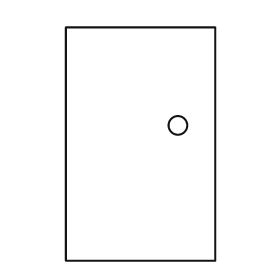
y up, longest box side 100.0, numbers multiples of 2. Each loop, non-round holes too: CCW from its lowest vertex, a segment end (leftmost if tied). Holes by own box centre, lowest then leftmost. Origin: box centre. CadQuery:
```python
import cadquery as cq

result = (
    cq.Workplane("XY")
    .moveTo(-32.0, -50.0)
    .lineTo(32.0, -50.0)
    .lineTo(32.0, 50.0)
    .lineTo(-32.0, 50.0)
    .close()
    .moveTo(16.0, 8.0)
    .circle(4.0)
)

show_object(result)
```